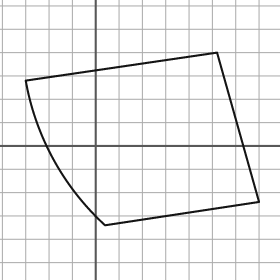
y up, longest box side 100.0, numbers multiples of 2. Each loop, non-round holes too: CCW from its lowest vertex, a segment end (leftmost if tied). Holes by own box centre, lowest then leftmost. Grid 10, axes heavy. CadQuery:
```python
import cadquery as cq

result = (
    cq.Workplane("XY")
    .moveTo(4.0, -34.0)
    .lineTo(70.0, -24.0)
    .lineTo(52.0, 40.0)
    .lineTo(-30.0, 28.0)
    .threePointArc((-18.0, -6.0), (4.0, -34.0))
    .close()
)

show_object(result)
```